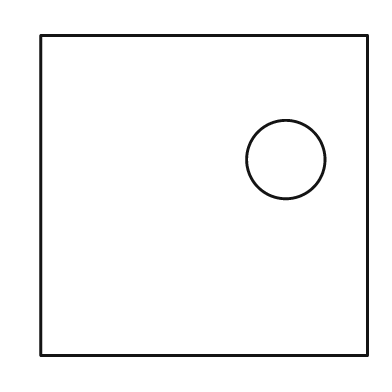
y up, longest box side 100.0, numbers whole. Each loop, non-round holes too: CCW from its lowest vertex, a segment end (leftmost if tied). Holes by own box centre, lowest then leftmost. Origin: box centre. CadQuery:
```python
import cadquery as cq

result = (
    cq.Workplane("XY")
    .moveTo(-50.0, -49.0)
    .lineTo(50.0, -49.0)
    .lineTo(50.0, 49.0)
    .lineTo(-50.0, 49.0)
    .close()
    .moveTo(25.0, 11.0)
    .circle(12.0)
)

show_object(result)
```